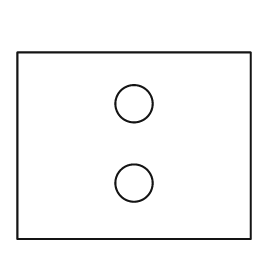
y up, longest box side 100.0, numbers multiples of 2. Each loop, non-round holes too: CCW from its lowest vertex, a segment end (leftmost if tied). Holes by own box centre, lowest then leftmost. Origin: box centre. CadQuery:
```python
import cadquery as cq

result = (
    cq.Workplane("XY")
    .moveTo(-50.0, -40.0)
    .lineTo(50.0, -40.0)
    .lineTo(50.0, 40.0)
    .lineTo(-50.0, 40.0)
    .close()
    .moveTo(0.0, -16.0)
    .circle(8.0)
    .moveTo(0.0, 18.0)
    .circle(8.0)
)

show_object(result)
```